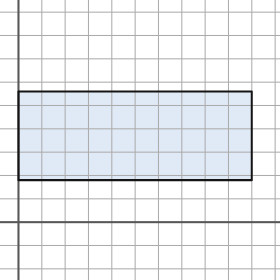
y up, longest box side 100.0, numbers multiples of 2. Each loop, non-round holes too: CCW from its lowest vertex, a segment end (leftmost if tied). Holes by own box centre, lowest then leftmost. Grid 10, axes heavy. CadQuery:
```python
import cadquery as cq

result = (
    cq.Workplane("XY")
    .moveTo(0.0, 18.0)
    .lineTo(100.0, 18.0)
    .lineTo(100.0, 56.0)
    .lineTo(0.0, 56.0)
    .close()
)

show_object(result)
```